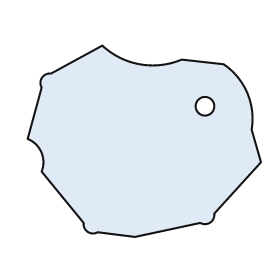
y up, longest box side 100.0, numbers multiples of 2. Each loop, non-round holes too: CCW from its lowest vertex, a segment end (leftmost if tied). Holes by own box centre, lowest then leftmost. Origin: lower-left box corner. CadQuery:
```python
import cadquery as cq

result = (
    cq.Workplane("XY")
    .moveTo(46.0, 0.0)
    .lineTo(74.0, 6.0)
    .threePointArc((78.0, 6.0), (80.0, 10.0))
    .lineTo(100.0, 32.0)
    .lineTo(96.0, 46.0)
    .threePointArc((94.0, 62.0), (84.0, 74.0))
    .lineTo(66.0, 76.0)
    .threePointArc((48.0, 74.0), (32.0, 82.0))
    .lineTo(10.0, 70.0)
    .threePointArc((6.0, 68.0), (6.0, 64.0))
    .lineTo(0.0, 42.0)
    .threePointArc((6.0, 36.0), (6.0, 28.0))
    .lineTo(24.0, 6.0)
    .threePointArc((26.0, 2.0), (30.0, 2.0))
    .close()
    .moveTo(76.0, 56.0)
    .circle(4.0)
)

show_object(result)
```